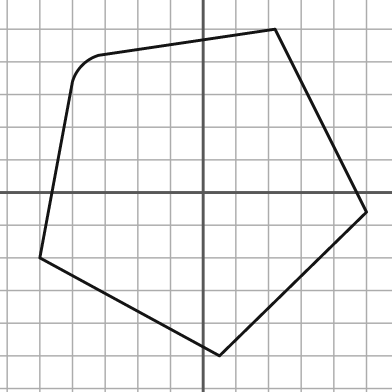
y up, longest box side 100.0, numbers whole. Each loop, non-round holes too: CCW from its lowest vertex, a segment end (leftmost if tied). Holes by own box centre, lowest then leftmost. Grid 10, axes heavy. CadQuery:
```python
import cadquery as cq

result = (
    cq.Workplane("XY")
    .moveTo(5.0, -50.0)
    .lineTo(50.0, -6.0)
    .lineTo(22.0, 50.0)
    .lineTo(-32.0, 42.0)
    .threePointArc((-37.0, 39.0), (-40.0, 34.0))
    .lineTo(-50.0, -20.0)
    .close()
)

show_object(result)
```